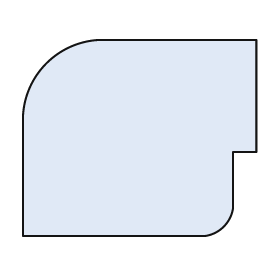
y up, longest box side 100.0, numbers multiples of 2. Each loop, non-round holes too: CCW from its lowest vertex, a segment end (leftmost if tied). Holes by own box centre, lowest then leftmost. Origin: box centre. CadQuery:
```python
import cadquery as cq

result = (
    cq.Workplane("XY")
    .moveTo(-50.0, -42.0)
    .lineTo(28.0, -42.0)
    .threePointArc((36.0, -38.0), (40.0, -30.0))
    .lineTo(40.0, -6.0)
    .lineTo(50.0, -6.0)
    .lineTo(50.0, 42.0)
    .lineTo(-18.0, 42.0)
    .threePointArc((-40.0, 32.0), (-50.0, 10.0))
    .close()
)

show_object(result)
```